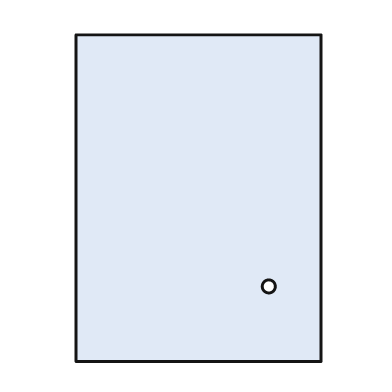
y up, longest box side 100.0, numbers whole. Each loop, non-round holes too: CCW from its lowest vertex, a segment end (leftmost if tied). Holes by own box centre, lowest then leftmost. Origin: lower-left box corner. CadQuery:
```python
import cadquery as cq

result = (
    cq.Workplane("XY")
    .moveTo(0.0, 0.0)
    .lineTo(75.0, 0.0)
    .lineTo(75.0, 100.0)
    .lineTo(0.0, 100.0)
    .close()
    .moveTo(59.0, 23.0)
    .circle(2.0)
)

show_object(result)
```